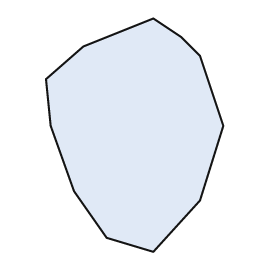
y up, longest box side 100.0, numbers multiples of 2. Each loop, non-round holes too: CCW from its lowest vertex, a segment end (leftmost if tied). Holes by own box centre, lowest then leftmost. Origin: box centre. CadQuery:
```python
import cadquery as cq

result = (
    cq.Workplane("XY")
    .moveTo(8.0, -50.0)
    .lineTo(28.0, -28.0)
    .lineTo(38.0, 4.0)
    .lineTo(28.0, 34.0)
    .lineTo(20.0, 42.0)
    .lineTo(8.0, 50.0)
    .lineTo(-22.0, 38.0)
    .lineTo(-38.0, 24.0)
    .lineTo(-36.0, 4.0)
    .lineTo(-26.0, -24.0)
    .lineTo(-12.0, -44.0)
    .close()
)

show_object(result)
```